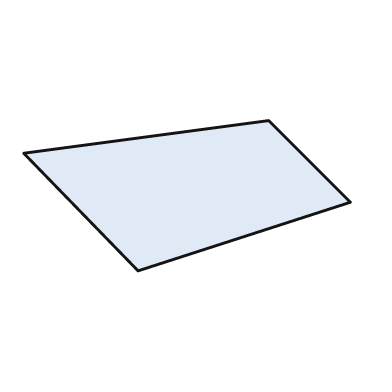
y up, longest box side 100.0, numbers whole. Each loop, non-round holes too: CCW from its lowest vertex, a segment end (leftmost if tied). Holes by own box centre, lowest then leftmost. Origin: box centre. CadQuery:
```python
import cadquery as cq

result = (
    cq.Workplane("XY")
    .moveTo(-15.0, -23.0)
    .lineTo(50.0, -2.0)
    .lineTo(25.0, 23.0)
    .lineTo(-50.0, 13.0)
    .close()
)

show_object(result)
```